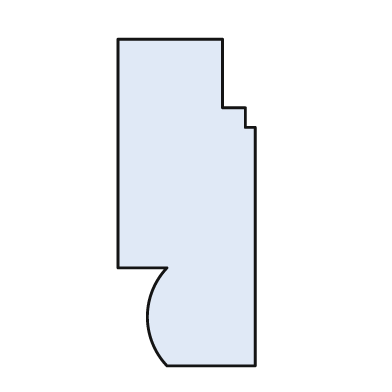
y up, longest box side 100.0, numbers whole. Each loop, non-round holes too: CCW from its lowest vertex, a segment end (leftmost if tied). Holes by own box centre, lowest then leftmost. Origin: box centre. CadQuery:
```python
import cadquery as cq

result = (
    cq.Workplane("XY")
    .moveTo(-6.0, -50.0)
    .lineTo(21.0, -50.0)
    .lineTo(21.0, 23.0)
    .lineTo(18.0, 23.0)
    .lineTo(18.0, 29.0)
    .lineTo(11.0, 29.0)
    .lineTo(11.0, 50.0)
    .lineTo(-21.0, 50.0)
    .lineTo(-21.0, -20.0)
    .lineTo(-6.0, -20.0)
    .threePointArc((-12.0, -35.0), (-6.0, -50.0))
    .close()
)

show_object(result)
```